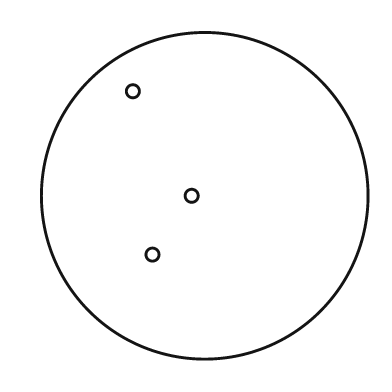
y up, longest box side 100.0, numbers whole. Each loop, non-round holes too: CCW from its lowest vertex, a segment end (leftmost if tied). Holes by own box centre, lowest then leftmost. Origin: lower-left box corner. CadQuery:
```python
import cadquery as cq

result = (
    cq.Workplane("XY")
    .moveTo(50.0, 50.0)
    .circle(50.0)
    .moveTo(34.0, 32.0)
    .circle(2.0)
    .moveTo(46.0, 50.0)
    .circle(2.0)
    .moveTo(28.0, 82.0)
    .circle(2.0)
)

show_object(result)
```